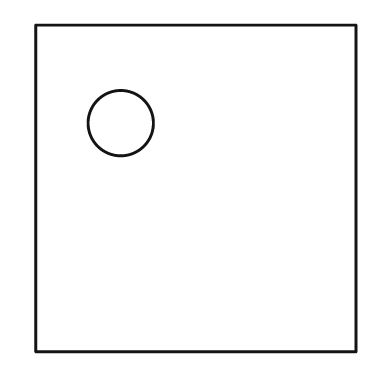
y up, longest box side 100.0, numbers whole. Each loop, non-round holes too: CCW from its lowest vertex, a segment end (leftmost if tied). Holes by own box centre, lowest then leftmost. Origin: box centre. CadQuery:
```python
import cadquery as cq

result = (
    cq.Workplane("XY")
    .moveTo(-49.0, -50.0)
    .lineTo(49.0, -50.0)
    .lineTo(49.0, 50.0)
    .lineTo(-49.0, 50.0)
    .close()
    .moveTo(-23.0, 20.0)
    .circle(10.0)
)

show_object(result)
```